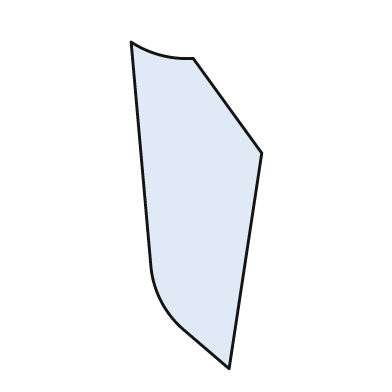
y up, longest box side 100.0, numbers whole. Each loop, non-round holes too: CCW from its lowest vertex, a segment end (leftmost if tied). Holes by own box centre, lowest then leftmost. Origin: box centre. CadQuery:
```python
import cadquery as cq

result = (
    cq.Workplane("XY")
    .moveTo(10.0, -50.0)
    .lineTo(20.0, 16.0)
    .lineTo(-1.0, 45.0)
    .threePointArc((-11.0, 46.0), (-20.0, 50.0))
    .lineTo(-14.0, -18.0)
    .threePointArc((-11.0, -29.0), (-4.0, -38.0))
    .close()
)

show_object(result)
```